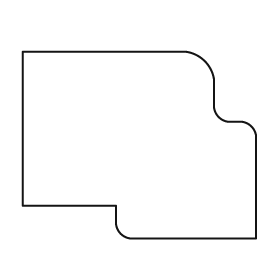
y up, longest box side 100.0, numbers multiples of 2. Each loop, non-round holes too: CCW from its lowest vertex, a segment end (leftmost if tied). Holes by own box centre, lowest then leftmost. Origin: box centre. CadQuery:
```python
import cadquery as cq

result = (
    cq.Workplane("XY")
    .moveTo(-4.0, -40.0)
    .lineTo(50.0, -40.0)
    .lineTo(50.0, 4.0)
    .threePointArc((48.0, 8.0), (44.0, 10.0))
    .lineTo(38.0, 10.0)
    .threePointArc((34.0, 12.0), (32.0, 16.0))
    .lineTo(32.0, 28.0)
    .threePointArc((28.0, 36.0), (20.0, 40.0))
    .lineTo(-50.0, 40.0)
    .lineTo(-50.0, -26.0)
    .lineTo(-10.0, -26.0)
    .lineTo(-10.0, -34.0)
    .threePointArc((-8.0, -38.0), (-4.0, -40.0))
    .close()
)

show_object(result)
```